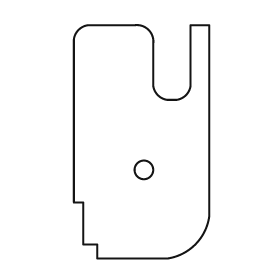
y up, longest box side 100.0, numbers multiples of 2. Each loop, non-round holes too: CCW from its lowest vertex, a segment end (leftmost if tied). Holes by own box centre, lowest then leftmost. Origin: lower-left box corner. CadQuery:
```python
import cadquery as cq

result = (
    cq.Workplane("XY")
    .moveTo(10.0, 0.0)
    .lineTo(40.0, 0.0)
    .threePointArc((52.0, 6.0), (58.0, 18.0))
    .lineTo(58.0, 100.0)
    .lineTo(50.0, 100.0)
    .lineTo(50.0, 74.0)
    .threePointArc((48.0, 70.0), (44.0, 68.0))
    .lineTo(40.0, 68.0)
    .threePointArc((36.0, 70.0), (34.0, 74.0))
    .lineTo(34.0, 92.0)
    .threePointArc((32.0, 98.0), (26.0, 100.0))
    .lineTo(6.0, 100.0)
    .threePointArc((2.0, 98.0), (0.0, 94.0))
    .lineTo(0.0, 24.0)
    .lineTo(4.0, 24.0)
    .lineTo(4.0, 6.0)
    .lineTo(10.0, 6.0)
    .close()
    .moveTo(30.0, 38.0)
    .circle(4.0)
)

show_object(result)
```